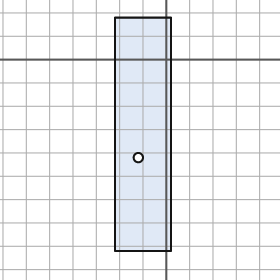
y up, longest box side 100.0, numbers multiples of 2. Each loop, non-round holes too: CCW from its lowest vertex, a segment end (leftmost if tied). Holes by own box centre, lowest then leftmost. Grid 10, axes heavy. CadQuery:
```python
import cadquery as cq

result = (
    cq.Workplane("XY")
    .moveTo(-22.0, -82.0)
    .lineTo(2.0, -82.0)
    .lineTo(2.0, 18.0)
    .lineTo(-22.0, 18.0)
    .close()
    .moveTo(-12.0, -42.0)
    .circle(2.0)
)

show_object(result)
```